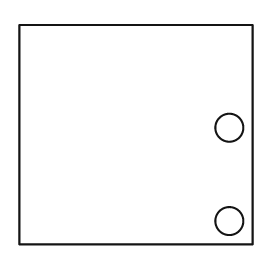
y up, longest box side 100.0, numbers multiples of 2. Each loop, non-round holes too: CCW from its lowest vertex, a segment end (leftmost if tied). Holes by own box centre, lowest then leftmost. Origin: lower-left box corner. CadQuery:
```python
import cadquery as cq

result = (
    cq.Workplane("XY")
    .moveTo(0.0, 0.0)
    .lineTo(100.0, 0.0)
    .lineTo(100.0, 94.0)
    .lineTo(0.0, 94.0)
    .close()
    .moveTo(90.0, 10.0)
    .circle(6.0)
    .moveTo(90.0, 50.0)
    .circle(6.0)
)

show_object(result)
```